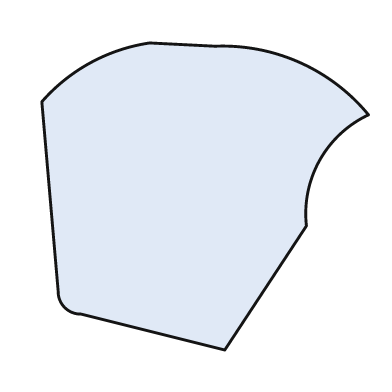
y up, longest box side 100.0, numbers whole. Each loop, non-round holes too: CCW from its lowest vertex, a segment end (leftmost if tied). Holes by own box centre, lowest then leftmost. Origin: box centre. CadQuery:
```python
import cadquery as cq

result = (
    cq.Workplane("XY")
    .moveTo(6.0, -47.0)
    .lineTo(31.0, -9.0)
    .threePointArc((35.0, 11.0), (50.0, 25.0))
    .threePointArc((29.0, 41.0), (3.0, 46.0))
    .lineTo(-17.0, 47.0)
    .threePointArc((-35.0, 41.0), (-50.0, 29.0))
    .lineTo(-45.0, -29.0)
    .threePointArc((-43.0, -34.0), (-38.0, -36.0))
    .close()
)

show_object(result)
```